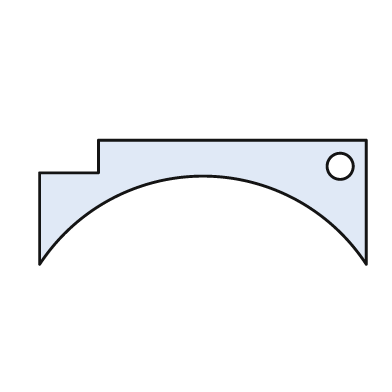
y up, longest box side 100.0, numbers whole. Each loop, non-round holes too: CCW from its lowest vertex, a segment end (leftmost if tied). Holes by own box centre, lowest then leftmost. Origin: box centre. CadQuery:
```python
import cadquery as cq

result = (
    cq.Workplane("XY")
    .moveTo(-50.0, -19.0)
    .threePointArc((0.0, 8.0), (50.0, -19.0))
    .lineTo(50.0, 19.0)
    .lineTo(-32.0, 19.0)
    .lineTo(-32.0, 9.0)
    .lineTo(-50.0, 9.0)
    .close()
    .moveTo(42.0, 11.0)
    .circle(4.0)
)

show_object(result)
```